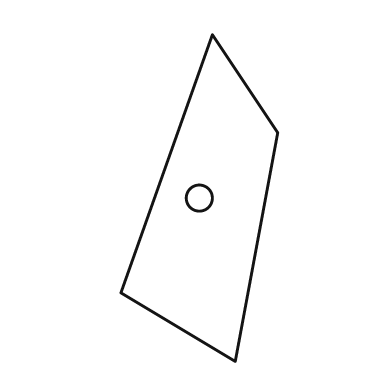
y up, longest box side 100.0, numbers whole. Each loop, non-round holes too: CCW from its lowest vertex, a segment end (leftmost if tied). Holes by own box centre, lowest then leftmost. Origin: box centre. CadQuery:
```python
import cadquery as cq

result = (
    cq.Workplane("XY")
    .moveTo(11.0, -50.0)
    .lineTo(24.0, 20.0)
    .lineTo(4.0, 50.0)
    .lineTo(-24.0, -29.0)
    .close()
    .moveTo(0.0, 0.0)
    .circle(4.0)
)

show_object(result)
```